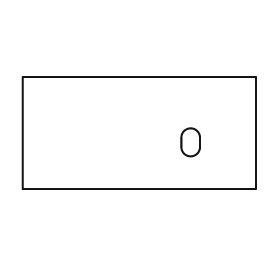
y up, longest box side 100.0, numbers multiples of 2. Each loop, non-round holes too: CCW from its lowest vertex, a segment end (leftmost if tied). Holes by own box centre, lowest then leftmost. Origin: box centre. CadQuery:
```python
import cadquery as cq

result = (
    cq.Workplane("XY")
    .moveTo(-50.0, -24.0)
    .lineTo(50.0, -24.0)
    .lineTo(50.0, 24.0)
    .lineTo(-50.0, 24.0)
    .close()
    .moveTo(18.0, -6.0)
    .threePointArc((22.0, -10.0), (26.0, -6.0))
    .lineTo(26.0, -2.0)
    .threePointArc((22.0, 2.0), (18.0, -2.0))
    .close()
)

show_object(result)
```